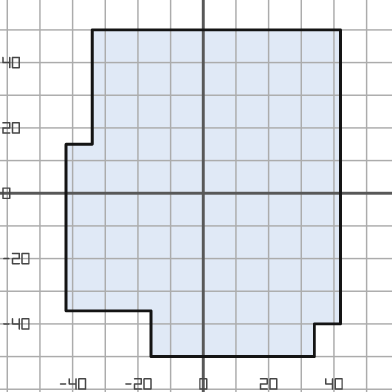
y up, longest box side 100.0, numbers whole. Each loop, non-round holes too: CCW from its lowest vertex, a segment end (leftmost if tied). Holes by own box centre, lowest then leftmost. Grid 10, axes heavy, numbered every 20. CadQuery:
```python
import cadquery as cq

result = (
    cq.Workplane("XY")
    .moveTo(-16.0, -50.0)
    .lineTo(34.0, -50.0)
    .lineTo(34.0, -40.0)
    .lineTo(42.0, -40.0)
    .lineTo(42.0, 50.0)
    .lineTo(-34.0, 50.0)
    .lineTo(-34.0, 15.0)
    .lineTo(-42.0, 15.0)
    .lineTo(-42.0, -36.0)
    .lineTo(-16.0, -36.0)
    .close()
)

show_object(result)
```